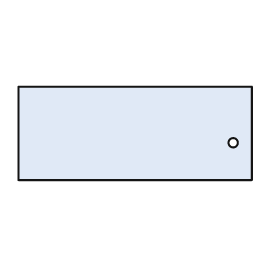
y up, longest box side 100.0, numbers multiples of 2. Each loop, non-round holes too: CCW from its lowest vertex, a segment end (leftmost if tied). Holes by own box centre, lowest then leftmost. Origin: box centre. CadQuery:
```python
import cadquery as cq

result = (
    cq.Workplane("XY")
    .moveTo(-50.0, -20.0)
    .lineTo(50.0, -20.0)
    .lineTo(50.0, 20.0)
    .lineTo(-50.0, 20.0)
    .close()
    .moveTo(42.0, -4.0)
    .circle(2.0)
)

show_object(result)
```